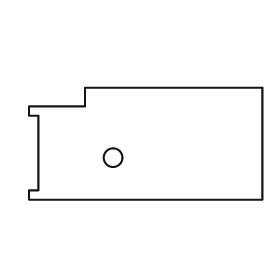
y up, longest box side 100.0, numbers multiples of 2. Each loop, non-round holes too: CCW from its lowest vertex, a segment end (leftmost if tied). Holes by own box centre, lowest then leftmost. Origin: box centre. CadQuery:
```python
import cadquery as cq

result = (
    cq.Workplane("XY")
    .moveTo(-50.0, -24.0)
    .lineTo(50.0, -24.0)
    .lineTo(50.0, 24.0)
    .lineTo(-26.0, 24.0)
    .lineTo(-26.0, 16.0)
    .lineTo(-50.0, 16.0)
    .lineTo(-50.0, 12.0)
    .lineTo(-46.0, 12.0)
    .lineTo(-46.0, -20.0)
    .lineTo(-50.0, -20.0)
    .close()
    .moveTo(-14.0, -6.0)
    .circle(4.0)
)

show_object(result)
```